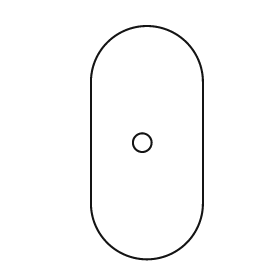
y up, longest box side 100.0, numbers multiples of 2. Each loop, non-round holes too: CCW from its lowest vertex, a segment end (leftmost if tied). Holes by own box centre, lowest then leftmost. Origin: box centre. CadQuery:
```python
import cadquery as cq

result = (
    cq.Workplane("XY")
    .moveTo(-24.0, -26.0)
    .threePointArc((0.0, -50.0), (24.0, -26.0))
    .lineTo(24.0, 26.0)
    .threePointArc((0.0, 50.0), (-24.0, 26.0))
    .close()
    .moveTo(-2.0, 0.0)
    .circle(4.0)
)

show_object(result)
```